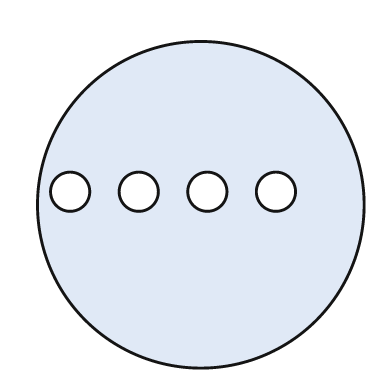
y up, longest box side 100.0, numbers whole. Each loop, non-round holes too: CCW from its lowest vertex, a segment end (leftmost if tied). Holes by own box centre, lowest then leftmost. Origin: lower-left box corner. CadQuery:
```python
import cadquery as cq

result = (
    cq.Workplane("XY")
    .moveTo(50.0, 50.0)
    .circle(50.0)
    .moveTo(10.0, 54.0)
    .circle(6.0)
    .moveTo(31.0, 54.0)
    .circle(6.0)
    .moveTo(52.0, 54.0)
    .circle(6.0)
    .moveTo(73.0, 54.0)
    .circle(6.0)
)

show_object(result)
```